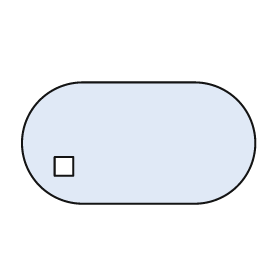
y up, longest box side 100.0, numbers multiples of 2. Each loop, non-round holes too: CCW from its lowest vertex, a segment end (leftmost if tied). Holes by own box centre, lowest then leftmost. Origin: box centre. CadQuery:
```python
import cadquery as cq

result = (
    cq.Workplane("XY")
    .moveTo(-24.0, -26.0)
    .lineTo(24.0, -26.0)
    .threePointArc((50.0, 0.0), (24.0, 26.0))
    .lineTo(-24.0, 26.0)
    .threePointArc((-50.0, 0.0), (-24.0, -26.0))
    .close()
    .moveTo(-36.0, -14.0)
    .lineTo(-28.0, -14.0)
    .lineTo(-28.0, -6.0)
    .lineTo(-36.0, -6.0)
    .close()
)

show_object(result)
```